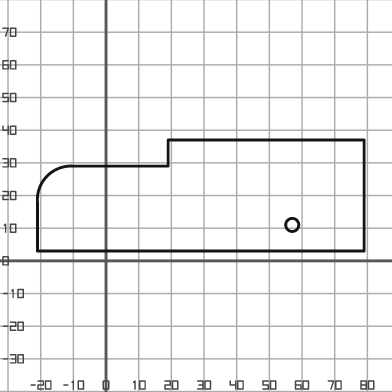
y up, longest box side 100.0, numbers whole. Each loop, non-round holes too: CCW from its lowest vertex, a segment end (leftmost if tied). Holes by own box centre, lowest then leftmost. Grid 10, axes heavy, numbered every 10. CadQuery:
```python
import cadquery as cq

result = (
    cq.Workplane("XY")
    .moveTo(-21.0, 3.0)
    .lineTo(79.0, 3.0)
    .lineTo(79.0, 37.0)
    .lineTo(19.0, 37.0)
    .lineTo(19.0, 29.0)
    .lineTo(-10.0, 29.0)
    .threePointArc((-18.0, 26.0), (-21.0, 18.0))
    .close()
    .moveTo(57.0, 11.0)
    .circle(2.0)
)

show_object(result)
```